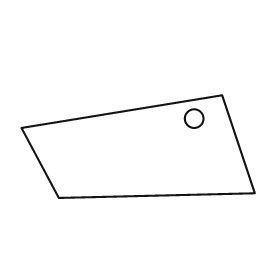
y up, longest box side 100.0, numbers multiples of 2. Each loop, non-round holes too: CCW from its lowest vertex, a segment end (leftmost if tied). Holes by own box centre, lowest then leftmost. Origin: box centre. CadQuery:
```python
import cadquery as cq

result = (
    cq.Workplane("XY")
    .moveTo(-34.0, -22.0)
    .lineTo(50.0, -20.0)
    .lineTo(36.0, 22.0)
    .lineTo(-50.0, 8.0)
    .close()
    .moveTo(24.0, 12.0)
    .circle(4.0)
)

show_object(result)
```